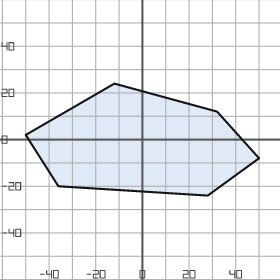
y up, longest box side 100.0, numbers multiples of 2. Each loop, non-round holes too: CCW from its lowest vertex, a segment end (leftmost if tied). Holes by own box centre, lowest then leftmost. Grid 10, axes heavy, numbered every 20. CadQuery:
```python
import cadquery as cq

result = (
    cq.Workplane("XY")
    .moveTo(28.0, -24.0)
    .lineTo(50.0, -8.0)
    .lineTo(32.0, 12.0)
    .lineTo(-12.0, 24.0)
    .lineTo(-50.0, 2.0)
    .lineTo(-36.0, -20.0)
    .close()
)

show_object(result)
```